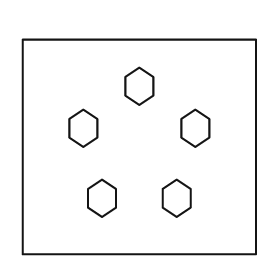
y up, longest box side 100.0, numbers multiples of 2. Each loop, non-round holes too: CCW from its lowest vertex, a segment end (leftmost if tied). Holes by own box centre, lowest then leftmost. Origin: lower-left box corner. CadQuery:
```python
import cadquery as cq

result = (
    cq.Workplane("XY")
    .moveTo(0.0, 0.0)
    .lineTo(100.0, 0.0)
    .lineTo(100.0, 92.0)
    .lineTo(0.0, 92.0)
    .close()
    .moveTo(34.0, 16.0)
    .lineTo(40.0, 20.0)
    .lineTo(40.0, 28.0)
    .lineTo(34.0, 32.0)
    .lineTo(28.0, 28.0)
    .lineTo(28.0, 20.0)
    .close()
    .moveTo(66.0, 16.0)
    .lineTo(72.0, 20.0)
    .lineTo(72.0, 28.0)
    .lineTo(66.0, 32.0)
    .lineTo(60.0, 28.0)
    .lineTo(60.0, 20.0)
    .close()
    .moveTo(26.0, 46.0)
    .lineTo(32.0, 50.0)
    .lineTo(32.0, 58.0)
    .lineTo(26.0, 62.0)
    .lineTo(20.0, 58.0)
    .lineTo(20.0, 50.0)
    .close()
    .moveTo(74.0, 46.0)
    .lineTo(80.0, 50.0)
    .lineTo(80.0, 58.0)
    .lineTo(74.0, 62.0)
    .lineTo(68.0, 58.0)
    .lineTo(68.0, 50.0)
    .close()
    .moveTo(50.0, 64.0)
    .lineTo(56.0, 68.0)
    .lineTo(56.0, 76.0)
    .lineTo(50.0, 80.0)
    .lineTo(44.0, 76.0)
    .lineTo(44.0, 68.0)
    .close()
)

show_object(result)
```